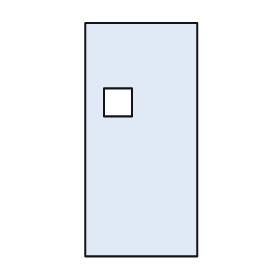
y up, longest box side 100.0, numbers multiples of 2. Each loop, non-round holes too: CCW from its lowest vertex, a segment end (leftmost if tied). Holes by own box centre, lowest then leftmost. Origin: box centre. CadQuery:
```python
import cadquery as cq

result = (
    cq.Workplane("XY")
    .moveTo(-24.0, -50.0)
    .lineTo(24.0, -50.0)
    .lineTo(24.0, 50.0)
    .lineTo(-24.0, 50.0)
    .close()
    .moveTo(-16.0, 10.0)
    .lineTo(-4.0, 10.0)
    .lineTo(-4.0, 22.0)
    .lineTo(-16.0, 22.0)
    .close()
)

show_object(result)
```